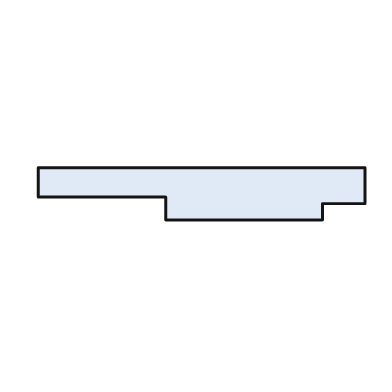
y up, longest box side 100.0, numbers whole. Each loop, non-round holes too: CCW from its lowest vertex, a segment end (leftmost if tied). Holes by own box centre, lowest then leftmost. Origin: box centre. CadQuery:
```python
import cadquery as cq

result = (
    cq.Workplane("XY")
    .moveTo(-11.0, -8.0)
    .lineTo(37.0, -8.0)
    .lineTo(37.0, -3.0)
    .lineTo(50.0, -3.0)
    .lineTo(50.0, 8.0)
    .lineTo(-50.0, 8.0)
    .lineTo(-50.0, -1.0)
    .lineTo(-11.0, -1.0)
    .close()
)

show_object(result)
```